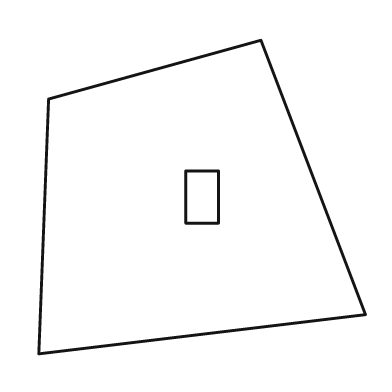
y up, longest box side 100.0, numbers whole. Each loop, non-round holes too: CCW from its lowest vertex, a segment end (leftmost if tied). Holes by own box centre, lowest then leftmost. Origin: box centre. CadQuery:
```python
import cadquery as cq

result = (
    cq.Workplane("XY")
    .moveTo(-50.0, -48.0)
    .lineTo(50.0, -36.0)
    .lineTo(18.0, 48.0)
    .lineTo(-47.0, 30.0)
    .close()
    .moveTo(-5.0, -8.0)
    .lineTo(5.0, -8.0)
    .lineTo(5.0, 8.0)
    .lineTo(-5.0, 8.0)
    .close()
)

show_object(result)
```